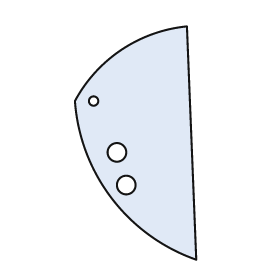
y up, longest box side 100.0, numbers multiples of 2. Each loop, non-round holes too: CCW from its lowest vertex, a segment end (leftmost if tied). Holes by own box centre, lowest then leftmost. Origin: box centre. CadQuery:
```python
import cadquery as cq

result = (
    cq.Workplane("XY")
    .moveTo(26.0, -50.0)
    .lineTo(22.0, 50.0)
    .threePointArc((-6.0, 40.0), (-26.0, 18.0))
    .threePointArc((-10.0, -24.0), (26.0, -50.0))
    .close()
    .moveTo(-4.0, -18.0)
    .circle(4.0)
    .moveTo(-8.0, -4.0)
    .circle(4.0)
    .moveTo(-18.0, 18.0)
    .circle(2.0)
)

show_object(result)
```